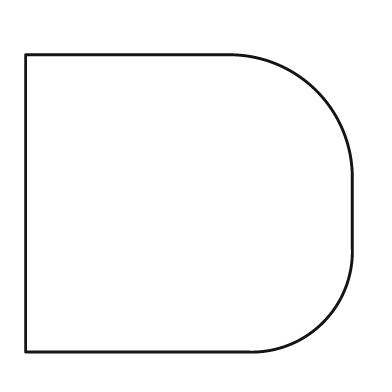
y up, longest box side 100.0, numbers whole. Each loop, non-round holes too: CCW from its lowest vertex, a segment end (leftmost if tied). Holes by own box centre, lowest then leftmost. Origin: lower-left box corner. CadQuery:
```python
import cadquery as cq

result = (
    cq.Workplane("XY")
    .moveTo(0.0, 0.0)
    .lineTo(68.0, 0.0)
    .threePointArc((91.0, 9.0), (100.0, 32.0))
    .lineTo(100.0, 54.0)
    .threePointArc((89.0, 80.0), (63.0, 91.0))
    .lineTo(0.0, 91.0)
    .close()
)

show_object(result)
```